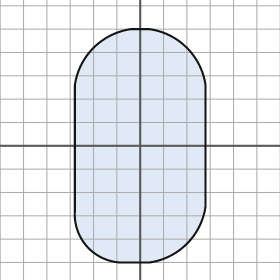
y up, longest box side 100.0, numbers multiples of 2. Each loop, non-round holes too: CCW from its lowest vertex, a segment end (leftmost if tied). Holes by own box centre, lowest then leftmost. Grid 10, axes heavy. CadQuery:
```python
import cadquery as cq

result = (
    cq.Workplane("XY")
    .moveTo(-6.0, -50.0)
    .lineTo(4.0, -50.0)
    .threePointArc((20.0, -42.0), (28.0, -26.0))
    .lineTo(28.0, 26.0)
    .threePointArc((20.0, 42.0), (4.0, 50.0))
    .lineTo(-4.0, 50.0)
    .threePointArc((-20.0, 42.0), (-28.0, 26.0))
    .lineTo(-28.0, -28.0)
    .threePointArc((-22.0, -44.0), (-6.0, -50.0))
    .close()
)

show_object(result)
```